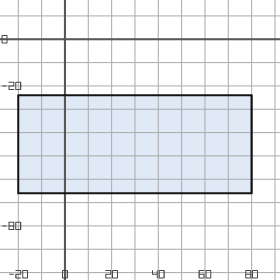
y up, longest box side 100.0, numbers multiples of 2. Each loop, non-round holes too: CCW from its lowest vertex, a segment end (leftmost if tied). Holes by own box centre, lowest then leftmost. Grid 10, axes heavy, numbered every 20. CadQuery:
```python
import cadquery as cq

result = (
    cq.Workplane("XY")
    .moveTo(-20.0, -66.0)
    .lineTo(80.0, -66.0)
    .lineTo(80.0, -24.0)
    .lineTo(-20.0, -24.0)
    .close()
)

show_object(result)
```